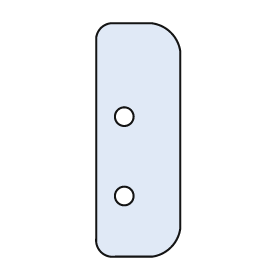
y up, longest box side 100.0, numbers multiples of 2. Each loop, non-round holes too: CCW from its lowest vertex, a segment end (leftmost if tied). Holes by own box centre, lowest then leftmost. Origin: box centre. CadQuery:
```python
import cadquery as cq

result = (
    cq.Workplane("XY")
    .moveTo(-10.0, -50.0)
    .lineTo(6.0, -50.0)
    .threePointArc((14.0, -46.0), (18.0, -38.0))
    .lineTo(18.0, 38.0)
    .threePointArc((14.0, 46.0), (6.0, 50.0))
    .lineTo(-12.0, 50.0)
    .threePointArc((-16.0, 48.0), (-18.0, 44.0))
    .lineTo(-18.0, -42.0)
    .threePointArc((-16.0, -48.0), (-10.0, -50.0))
    .close()
    .moveTo(-6.0, -24.0)
    .circle(4.0)
    .moveTo(-6.0, 10.0)
    .circle(4.0)
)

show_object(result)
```